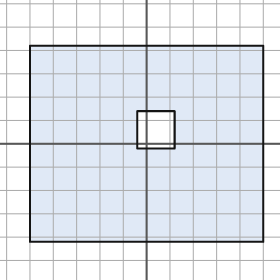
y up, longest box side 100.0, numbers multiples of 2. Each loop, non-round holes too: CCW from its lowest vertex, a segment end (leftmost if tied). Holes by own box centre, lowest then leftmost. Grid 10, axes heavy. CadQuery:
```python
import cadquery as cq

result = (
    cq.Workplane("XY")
    .moveTo(-50.0, -42.0)
    .lineTo(50.0, -42.0)
    .lineTo(50.0, 42.0)
    .lineTo(-50.0, 42.0)
    .close()
    .moveTo(-4.0, -2.0)
    .lineTo(12.0, -2.0)
    .lineTo(12.0, 14.0)
    .lineTo(-4.0, 14.0)
    .close()
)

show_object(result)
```